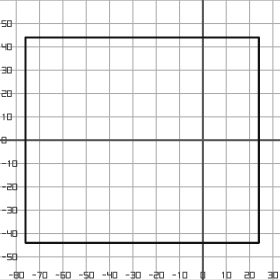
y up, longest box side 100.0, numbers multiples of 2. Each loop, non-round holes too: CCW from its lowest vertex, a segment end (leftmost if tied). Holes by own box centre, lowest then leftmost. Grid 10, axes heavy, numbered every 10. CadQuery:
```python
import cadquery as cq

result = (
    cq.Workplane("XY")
    .moveTo(-76.0, -44.0)
    .lineTo(24.0, -44.0)
    .lineTo(24.0, 44.0)
    .lineTo(-76.0, 44.0)
    .close()
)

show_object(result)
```